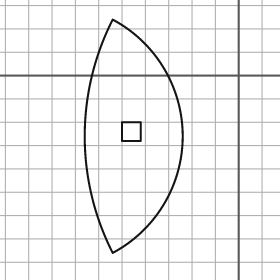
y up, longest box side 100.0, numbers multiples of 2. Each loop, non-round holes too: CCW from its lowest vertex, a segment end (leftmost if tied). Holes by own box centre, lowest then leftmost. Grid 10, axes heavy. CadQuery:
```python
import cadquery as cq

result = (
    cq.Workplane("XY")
    .moveTo(-54.0, -76.0)
    .threePointArc((-24.0, -26.0), (-54.0, 24.0))
    .threePointArc((-66.0, -26.0), (-54.0, -76.0))
    .close()
    .moveTo(-50.0, -28.0)
    .lineTo(-42.0, -28.0)
    .lineTo(-42.0, -20.0)
    .lineTo(-50.0, -20.0)
    .close()
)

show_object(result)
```